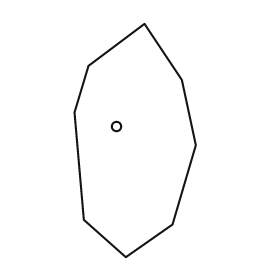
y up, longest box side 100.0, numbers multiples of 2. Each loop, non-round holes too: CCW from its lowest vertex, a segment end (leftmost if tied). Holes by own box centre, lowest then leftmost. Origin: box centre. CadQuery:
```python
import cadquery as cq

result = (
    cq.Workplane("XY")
    .moveTo(-4.0, -50.0)
    .lineTo(16.0, -36.0)
    .lineTo(26.0, -2.0)
    .lineTo(20.0, 26.0)
    .lineTo(4.0, 50.0)
    .lineTo(-20.0, 32.0)
    .lineTo(-26.0, 12.0)
    .lineTo(-22.0, -34.0)
    .close()
    .moveTo(-8.0, 6.0)
    .circle(2.0)
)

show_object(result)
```